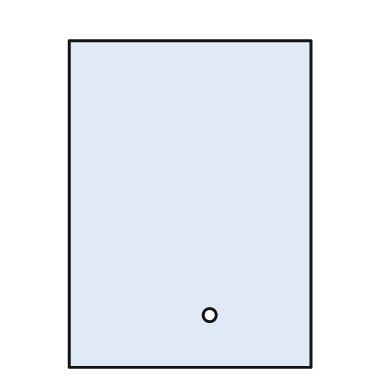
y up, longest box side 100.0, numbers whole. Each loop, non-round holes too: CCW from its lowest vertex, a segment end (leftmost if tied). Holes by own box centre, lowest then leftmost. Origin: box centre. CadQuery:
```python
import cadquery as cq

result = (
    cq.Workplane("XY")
    .moveTo(-37.0, -50.0)
    .lineTo(37.0, -50.0)
    .lineTo(37.0, 50.0)
    .lineTo(-37.0, 50.0)
    .close()
    .moveTo(6.0, -34.0)
    .circle(2.0)
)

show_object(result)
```